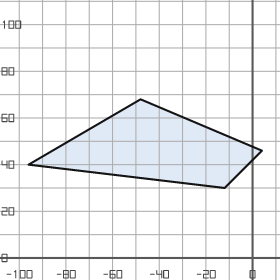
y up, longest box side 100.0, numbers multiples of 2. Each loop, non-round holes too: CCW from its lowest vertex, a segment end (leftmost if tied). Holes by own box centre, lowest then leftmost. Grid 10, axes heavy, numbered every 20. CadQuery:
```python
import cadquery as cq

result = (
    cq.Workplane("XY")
    .moveTo(-12.0, 30.0)
    .lineTo(4.0, 46.0)
    .lineTo(-48.0, 68.0)
    .lineTo(-96.0, 40.0)
    .close()
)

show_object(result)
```